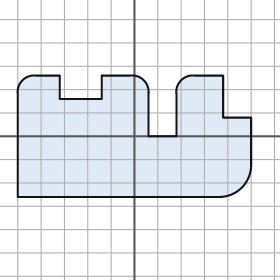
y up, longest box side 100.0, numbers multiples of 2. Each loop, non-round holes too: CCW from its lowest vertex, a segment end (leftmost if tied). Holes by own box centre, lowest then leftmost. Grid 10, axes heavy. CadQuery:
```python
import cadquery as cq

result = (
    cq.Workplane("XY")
    .moveTo(-50.0, -26.0)
    .lineTo(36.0, -26.0)
    .threePointArc((46.0, -22.0), (50.0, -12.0))
    .lineTo(50.0, 8.0)
    .lineTo(38.0, 8.0)
    .lineTo(38.0, 26.0)
    .lineTo(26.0, 26.0)
    .threePointArc((20.0, 24.0), (18.0, 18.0))
    .lineTo(18.0, 0.0)
    .lineTo(6.0, 0.0)
    .lineTo(6.0, 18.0)
    .threePointArc((4.0, 24.0), (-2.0, 26.0))
    .lineTo(-14.0, 26.0)
    .lineTo(-14.0, 16.0)
    .lineTo(-32.0, 16.0)
    .lineTo(-32.0, 26.0)
    .lineTo(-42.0, 26.0)
    .threePointArc((-48.0, 24.0), (-50.0, 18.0))
    .close()
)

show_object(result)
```